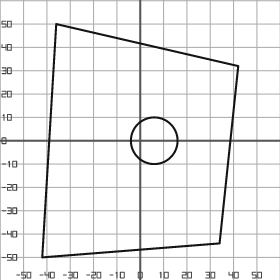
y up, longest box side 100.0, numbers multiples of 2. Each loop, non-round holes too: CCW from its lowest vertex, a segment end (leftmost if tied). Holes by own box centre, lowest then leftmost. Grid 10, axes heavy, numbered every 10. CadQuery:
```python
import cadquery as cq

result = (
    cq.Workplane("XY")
    .moveTo(-42.0, -50.0)
    .lineTo(34.0, -44.0)
    .lineTo(42.0, 32.0)
    .lineTo(-36.0, 50.0)
    .close()
    .moveTo(6.0, 0.0)
    .circle(10.0)
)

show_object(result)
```